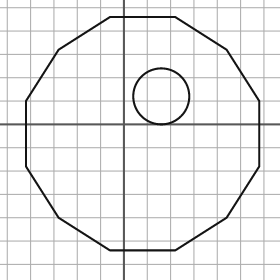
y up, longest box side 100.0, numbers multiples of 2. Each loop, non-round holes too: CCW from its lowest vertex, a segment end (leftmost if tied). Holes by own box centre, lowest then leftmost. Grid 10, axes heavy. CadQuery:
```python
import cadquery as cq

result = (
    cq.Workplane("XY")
    .moveTo(-6.0, -54.0)
    .lineTo(22.0, -54.0)
    .lineTo(44.0, -40.0)
    .lineTo(58.0, -18.0)
    .lineTo(58.0, 10.0)
    .lineTo(44.0, 32.0)
    .lineTo(22.0, 46.0)
    .lineTo(-6.0, 46.0)
    .lineTo(-28.0, 32.0)
    .lineTo(-42.0, 10.0)
    .lineTo(-42.0, -18.0)
    .lineTo(-28.0, -40.0)
    .close()
    .moveTo(16.0, 12.0)
    .circle(12.0)
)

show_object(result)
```